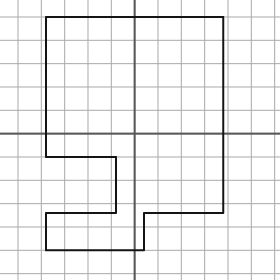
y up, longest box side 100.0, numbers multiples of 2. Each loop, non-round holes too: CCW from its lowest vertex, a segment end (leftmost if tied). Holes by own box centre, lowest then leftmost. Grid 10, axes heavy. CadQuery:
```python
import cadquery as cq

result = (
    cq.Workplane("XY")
    .moveTo(-38.0, -50.0)
    .lineTo(4.0, -50.0)
    .lineTo(4.0, -34.0)
    .lineTo(38.0, -34.0)
    .lineTo(38.0, 50.0)
    .lineTo(-38.0, 50.0)
    .lineTo(-38.0, -10.0)
    .lineTo(-8.0, -10.0)
    .lineTo(-8.0, -34.0)
    .lineTo(-38.0, -34.0)
    .close()
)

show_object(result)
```